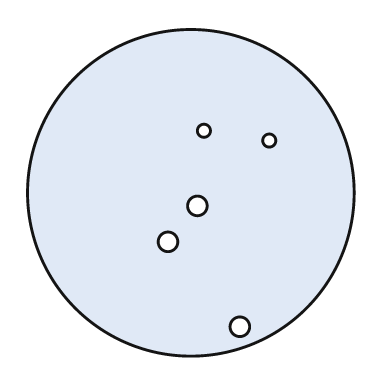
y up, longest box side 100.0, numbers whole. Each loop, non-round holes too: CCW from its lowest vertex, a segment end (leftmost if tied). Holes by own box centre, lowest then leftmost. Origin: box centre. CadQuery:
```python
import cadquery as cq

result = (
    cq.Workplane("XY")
    .moveTo(0.0, 0.0)
    .circle(50.0)
    .moveTo(15.0, -41.0)
    .circle(3.0)
    .moveTo(-7.0, -15.0)
    .circle(3.0)
    .moveTo(2.0, -4.0)
    .circle(3.0)
    .moveTo(24.0, 16.0)
    .circle(2.0)
    .moveTo(4.0, 19.0)
    .circle(2.0)
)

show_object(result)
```